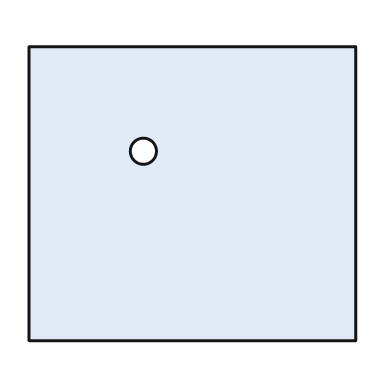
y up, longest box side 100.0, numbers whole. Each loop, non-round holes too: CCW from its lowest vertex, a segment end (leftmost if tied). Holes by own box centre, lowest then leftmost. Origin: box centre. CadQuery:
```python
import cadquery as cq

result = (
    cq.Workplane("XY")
    .moveTo(-50.0, -45.0)
    .lineTo(50.0, -45.0)
    .lineTo(50.0, 45.0)
    .lineTo(-50.0, 45.0)
    .close()
    .moveTo(-15.0, 13.0)
    .circle(4.0)
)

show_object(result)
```